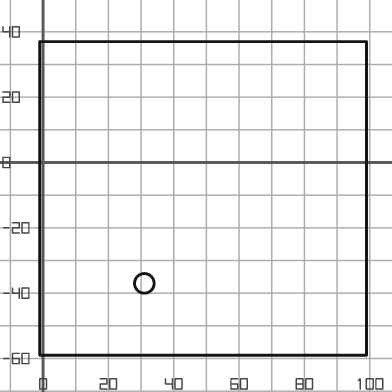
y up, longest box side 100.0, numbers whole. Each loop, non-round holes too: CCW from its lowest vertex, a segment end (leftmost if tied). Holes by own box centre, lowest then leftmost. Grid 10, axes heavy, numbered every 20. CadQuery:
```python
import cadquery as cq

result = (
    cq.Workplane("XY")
    .moveTo(-1.0, -59.0)
    .lineTo(99.0, -59.0)
    .lineTo(99.0, 37.0)
    .lineTo(-1.0, 37.0)
    .close()
    .moveTo(31.0, -37.0)
    .circle(3.0)
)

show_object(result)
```